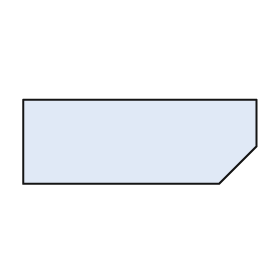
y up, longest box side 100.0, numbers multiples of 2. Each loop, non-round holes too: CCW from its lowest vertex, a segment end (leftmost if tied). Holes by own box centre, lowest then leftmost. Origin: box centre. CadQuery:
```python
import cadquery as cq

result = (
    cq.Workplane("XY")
    .moveTo(-50.0, -18.0)
    .lineTo(34.0, -18.0)
    .lineTo(50.0, -2.0)
    .lineTo(50.0, 18.0)
    .lineTo(-50.0, 18.0)
    .close()
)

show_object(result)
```